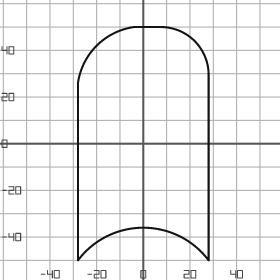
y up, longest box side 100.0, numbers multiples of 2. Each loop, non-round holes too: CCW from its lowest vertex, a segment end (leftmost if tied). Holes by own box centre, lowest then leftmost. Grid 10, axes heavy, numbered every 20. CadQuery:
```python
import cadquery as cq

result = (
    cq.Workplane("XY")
    .moveTo(-28.0, -50.0)
    .threePointArc((0.0, -36.0), (28.0, -50.0))
    .lineTo(28.0, 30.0)
    .threePointArc((22.0, 44.0), (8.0, 50.0))
    .lineTo(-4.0, 50.0)
    .threePointArc((-20.0, 42.0), (-28.0, 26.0))
    .close()
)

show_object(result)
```